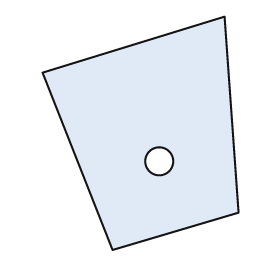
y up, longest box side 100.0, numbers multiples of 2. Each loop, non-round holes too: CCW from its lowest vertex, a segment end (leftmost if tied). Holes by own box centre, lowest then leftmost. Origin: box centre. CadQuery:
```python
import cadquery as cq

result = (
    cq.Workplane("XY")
    .moveTo(-12.0, -50.0)
    .lineTo(42.0, -34.0)
    .lineTo(36.0, 50.0)
    .lineTo(-42.0, 26.0)
    .close()
    .moveTo(8.0, -12.0)
    .circle(6.0)
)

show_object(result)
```